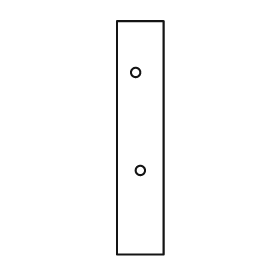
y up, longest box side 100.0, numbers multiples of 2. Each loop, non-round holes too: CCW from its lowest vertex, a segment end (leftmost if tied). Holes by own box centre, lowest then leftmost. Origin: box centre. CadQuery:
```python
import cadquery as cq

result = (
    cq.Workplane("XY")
    .moveTo(-10.0, -50.0)
    .lineTo(10.0, -50.0)
    .lineTo(10.0, 50.0)
    .lineTo(-10.0, 50.0)
    .close()
    .moveTo(0.0, -14.0)
    .circle(2.0)
    .moveTo(-2.0, 28.0)
    .circle(2.0)
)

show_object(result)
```